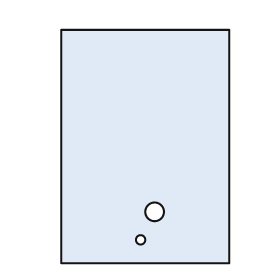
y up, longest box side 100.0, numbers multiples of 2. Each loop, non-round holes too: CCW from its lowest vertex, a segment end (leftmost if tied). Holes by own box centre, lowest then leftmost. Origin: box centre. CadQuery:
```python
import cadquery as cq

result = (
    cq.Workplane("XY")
    .moveTo(-36.0, -50.0)
    .lineTo(36.0, -50.0)
    .lineTo(36.0, 50.0)
    .lineTo(-36.0, 50.0)
    .close()
    .moveTo(-2.0, -40.0)
    .circle(2.0)
    .moveTo(4.0, -28.0)
    .circle(4.0)
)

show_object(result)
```